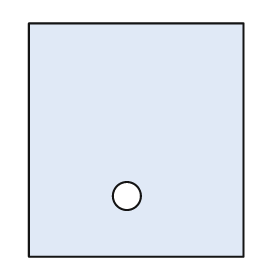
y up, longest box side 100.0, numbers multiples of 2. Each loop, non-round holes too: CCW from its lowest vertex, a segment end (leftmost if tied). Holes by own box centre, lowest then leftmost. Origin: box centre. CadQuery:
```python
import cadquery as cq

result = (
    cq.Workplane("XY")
    .moveTo(-46.0, -50.0)
    .lineTo(46.0, -50.0)
    .lineTo(46.0, 50.0)
    .lineTo(-46.0, 50.0)
    .close()
    .moveTo(-4.0, -24.0)
    .circle(6.0)
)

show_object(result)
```